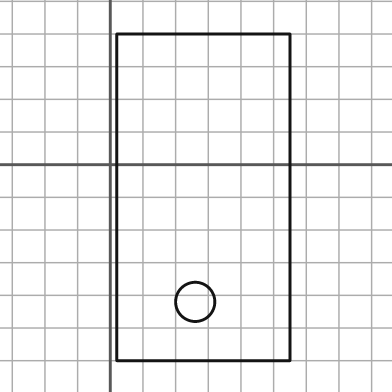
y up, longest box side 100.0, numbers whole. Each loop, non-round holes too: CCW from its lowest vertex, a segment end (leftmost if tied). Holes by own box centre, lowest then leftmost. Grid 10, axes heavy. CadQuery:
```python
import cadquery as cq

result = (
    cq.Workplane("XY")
    .moveTo(2.0, -60.0)
    .lineTo(55.0, -60.0)
    .lineTo(55.0, 40.0)
    .lineTo(2.0, 40.0)
    .close()
    .moveTo(26.0, -42.0)
    .circle(6.0)
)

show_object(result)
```